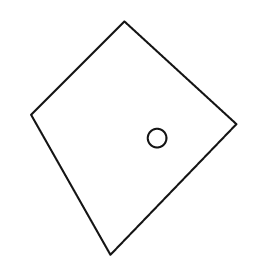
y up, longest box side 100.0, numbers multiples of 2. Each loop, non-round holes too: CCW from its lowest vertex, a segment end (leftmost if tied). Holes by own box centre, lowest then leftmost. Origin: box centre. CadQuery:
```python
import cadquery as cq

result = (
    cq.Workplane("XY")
    .moveTo(-10.0, -50.0)
    .lineTo(44.0, 6.0)
    .lineTo(-4.0, 50.0)
    .lineTo(-44.0, 10.0)
    .close()
    .moveTo(10.0, 0.0)
    .circle(4.0)
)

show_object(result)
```